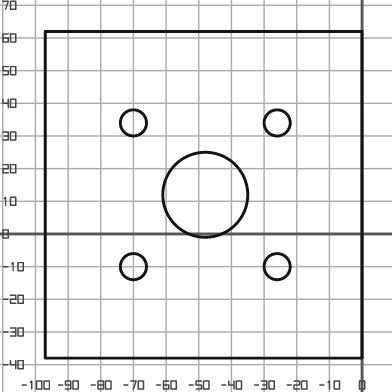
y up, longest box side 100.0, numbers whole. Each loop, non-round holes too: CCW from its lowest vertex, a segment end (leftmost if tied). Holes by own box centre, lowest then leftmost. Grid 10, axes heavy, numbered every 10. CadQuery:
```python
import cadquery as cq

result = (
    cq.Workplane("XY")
    .moveTo(-97.0, -38.0)
    .lineTo(0.0, -38.0)
    .lineTo(0.0, 62.0)
    .lineTo(-97.0, 62.0)
    .close()
    .moveTo(-70.0, -10.0)
    .circle(4.0)
    .moveTo(-26.0, -10.0)
    .circle(4.0)
    .moveTo(-48.0, 12.0)
    .circle(13.0)
    .moveTo(-70.0, 34.0)
    .circle(4.0)
    .moveTo(-26.0, 34.0)
    .circle(4.0)
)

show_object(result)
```